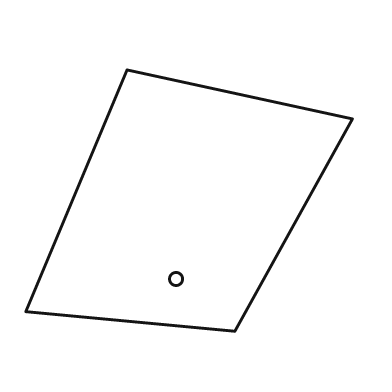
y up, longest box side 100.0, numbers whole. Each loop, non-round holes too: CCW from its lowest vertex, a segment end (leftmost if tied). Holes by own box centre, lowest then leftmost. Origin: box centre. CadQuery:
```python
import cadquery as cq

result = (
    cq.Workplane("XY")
    .moveTo(14.0, -40.0)
    .lineTo(50.0, 25.0)
    .lineTo(-19.0, 40.0)
    .lineTo(-50.0, -34.0)
    .close()
    .moveTo(-4.0, -24.0)
    .circle(2.0)
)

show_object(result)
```